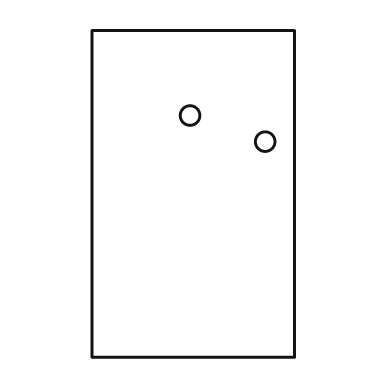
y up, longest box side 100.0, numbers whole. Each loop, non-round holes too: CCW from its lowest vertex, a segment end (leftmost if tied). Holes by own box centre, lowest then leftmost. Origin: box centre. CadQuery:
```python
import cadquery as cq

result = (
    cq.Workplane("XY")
    .moveTo(-31.0, -50.0)
    .lineTo(31.0, -50.0)
    .lineTo(31.0, 50.0)
    .lineTo(-31.0, 50.0)
    .close()
    .moveTo(22.0, 16.0)
    .circle(3.0)
    .moveTo(-1.0, 24.0)
    .circle(3.0)
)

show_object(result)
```